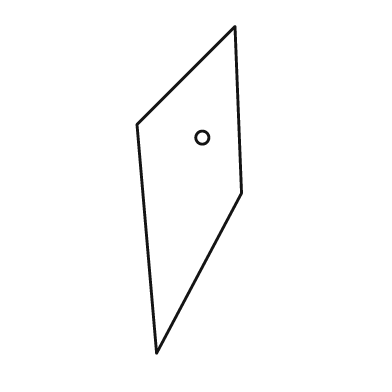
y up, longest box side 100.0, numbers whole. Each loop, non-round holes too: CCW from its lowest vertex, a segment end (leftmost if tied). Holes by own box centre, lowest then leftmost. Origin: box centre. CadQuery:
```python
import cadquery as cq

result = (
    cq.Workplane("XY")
    .moveTo(-10.0, -50.0)
    .lineTo(16.0, -1.0)
    .lineTo(14.0, 50.0)
    .lineTo(-16.0, 20.0)
    .close()
    .moveTo(4.0, 16.0)
    .circle(2.0)
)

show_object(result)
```